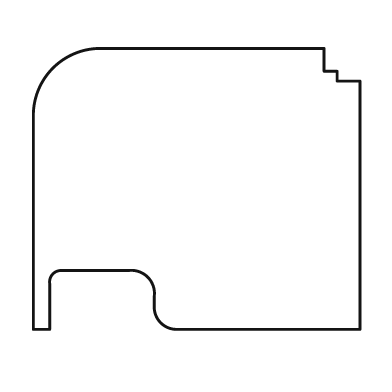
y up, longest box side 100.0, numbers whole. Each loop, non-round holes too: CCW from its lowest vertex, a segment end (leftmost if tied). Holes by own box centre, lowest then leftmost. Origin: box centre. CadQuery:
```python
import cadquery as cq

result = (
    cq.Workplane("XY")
    .moveTo(-50.0, -43.0)
    .lineTo(-45.0, -43.0)
    .lineTo(-45.0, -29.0)
    .threePointArc((-44.0, -26.0), (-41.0, -25.0))
    .lineTo(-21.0, -25.0)
    .threePointArc((-15.0, -27.0), (-13.0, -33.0))
    .lineTo(-13.0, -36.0)
    .threePointArc((-11.0, -41.0), (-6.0, -43.0))
    .lineTo(50.0, -43.0)
    .lineTo(50.0, 33.0)
    .lineTo(43.0, 33.0)
    .lineTo(43.0, 36.0)
    .lineTo(39.0, 36.0)
    .lineTo(39.0, 43.0)
    .lineTo(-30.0, 43.0)
    .threePointArc((-44.0, 37.0), (-50.0, 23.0))
    .close()
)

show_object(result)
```